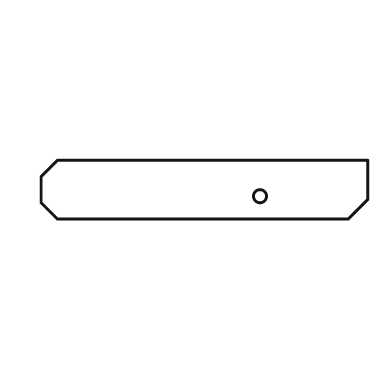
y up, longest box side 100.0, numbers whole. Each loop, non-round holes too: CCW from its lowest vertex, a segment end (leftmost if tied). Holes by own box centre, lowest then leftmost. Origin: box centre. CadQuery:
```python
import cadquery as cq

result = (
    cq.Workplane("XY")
    .moveTo(-45.0, -9.0)
    .lineTo(44.0, -9.0)
    .lineTo(50.0, -3.0)
    .lineTo(50.0, 9.0)
    .lineTo(-45.0, 9.0)
    .lineTo(-50.0, 4.0)
    .lineTo(-50.0, -4.0)
    .close()
    .moveTo(17.0, -2.0)
    .circle(2.0)
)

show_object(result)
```